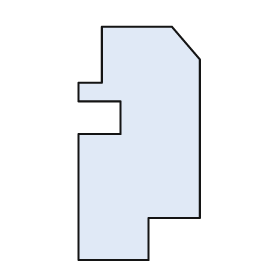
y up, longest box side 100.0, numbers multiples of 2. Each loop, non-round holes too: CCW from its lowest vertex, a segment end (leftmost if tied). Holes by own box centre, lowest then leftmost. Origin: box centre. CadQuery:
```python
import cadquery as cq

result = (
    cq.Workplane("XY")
    .moveTo(-26.0, -50.0)
    .lineTo(4.0, -50.0)
    .lineTo(4.0, -32.0)
    .lineTo(26.0, -32.0)
    .lineTo(26.0, 36.0)
    .lineTo(14.0, 50.0)
    .lineTo(-16.0, 50.0)
    .lineTo(-16.0, 26.0)
    .lineTo(-26.0, 26.0)
    .lineTo(-26.0, 18.0)
    .lineTo(-8.0, 18.0)
    .lineTo(-8.0, 4.0)
    .lineTo(-26.0, 4.0)
    .close()
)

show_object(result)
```